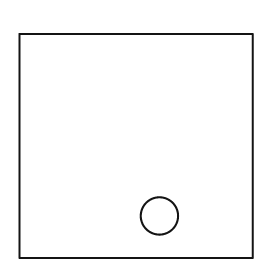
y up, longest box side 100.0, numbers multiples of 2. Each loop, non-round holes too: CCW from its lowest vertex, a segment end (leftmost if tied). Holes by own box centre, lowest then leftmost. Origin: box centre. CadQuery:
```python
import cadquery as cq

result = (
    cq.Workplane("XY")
    .moveTo(-50.0, -48.0)
    .lineTo(50.0, -48.0)
    .lineTo(50.0, 48.0)
    .lineTo(-50.0, 48.0)
    .close()
    .moveTo(10.0, -30.0)
    .circle(8.0)
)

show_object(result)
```